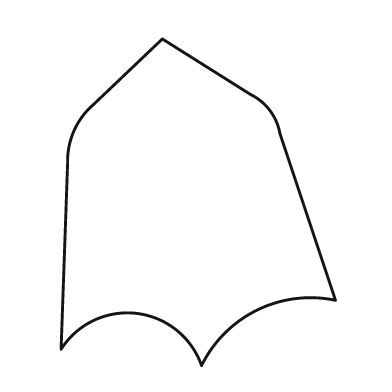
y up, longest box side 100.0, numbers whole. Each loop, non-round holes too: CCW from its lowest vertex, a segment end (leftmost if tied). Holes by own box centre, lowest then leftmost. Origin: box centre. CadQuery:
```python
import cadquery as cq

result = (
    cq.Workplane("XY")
    .moveTo(1.0, -50.0)
    .threePointArc((18.0, -33.0), (42.0, -30.0))
    .lineTo(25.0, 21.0)
    .threePointArc((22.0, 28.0), (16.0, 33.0))
    .lineTo(-11.0, 50.0)
    .lineTo(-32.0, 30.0)
    .threePointArc((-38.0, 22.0), (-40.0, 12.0))
    .lineTo(-42.0, -45.0)
    .threePointArc((-19.0, -34.0), (1.0, -50.0))
    .close()
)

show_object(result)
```